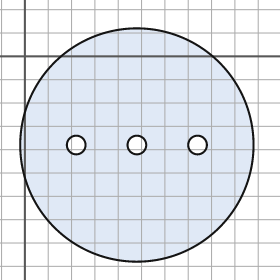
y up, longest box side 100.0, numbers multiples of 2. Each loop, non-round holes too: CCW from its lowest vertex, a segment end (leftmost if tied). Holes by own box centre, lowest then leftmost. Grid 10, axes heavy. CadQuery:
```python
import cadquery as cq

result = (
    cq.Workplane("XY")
    .moveTo(48.0, -38.0)
    .circle(50.0)
    .moveTo(22.0, -38.0)
    .circle(4.0)
    .moveTo(48.0, -38.0)
    .circle(4.0)
    .moveTo(74.0, -38.0)
    .circle(4.0)
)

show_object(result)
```